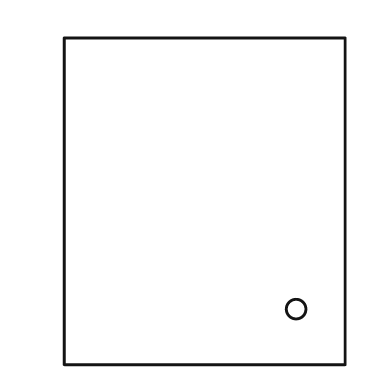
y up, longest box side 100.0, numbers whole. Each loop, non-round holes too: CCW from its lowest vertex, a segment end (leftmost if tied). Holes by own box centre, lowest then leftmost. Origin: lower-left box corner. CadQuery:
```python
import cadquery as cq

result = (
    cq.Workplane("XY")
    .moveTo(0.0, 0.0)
    .lineTo(86.0, 0.0)
    .lineTo(86.0, 100.0)
    .lineTo(0.0, 100.0)
    .close()
    .moveTo(71.0, 17.0)
    .circle(3.0)
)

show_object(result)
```